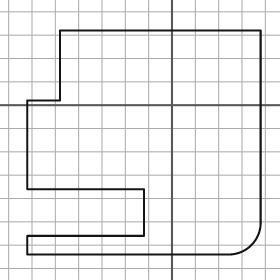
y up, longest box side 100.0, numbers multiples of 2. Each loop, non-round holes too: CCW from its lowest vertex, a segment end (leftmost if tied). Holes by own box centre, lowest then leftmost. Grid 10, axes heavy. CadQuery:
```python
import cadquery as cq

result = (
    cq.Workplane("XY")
    .moveTo(-62.0, -64.0)
    .lineTo(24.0, -64.0)
    .threePointArc((34.0, -60.0), (38.0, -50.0))
    .lineTo(38.0, 32.0)
    .lineTo(-48.0, 32.0)
    .lineTo(-48.0, 2.0)
    .lineTo(-62.0, 2.0)
    .lineTo(-62.0, -36.0)
    .lineTo(-12.0, -36.0)
    .lineTo(-12.0, -56.0)
    .lineTo(-62.0, -56.0)
    .close()
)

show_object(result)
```